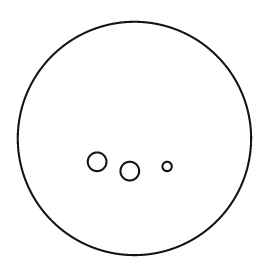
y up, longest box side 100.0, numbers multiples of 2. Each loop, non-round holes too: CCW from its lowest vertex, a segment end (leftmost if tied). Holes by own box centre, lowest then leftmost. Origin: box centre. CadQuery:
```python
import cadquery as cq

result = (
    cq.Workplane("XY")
    .moveTo(0.0, 0.0)
    .circle(50.0)
    .moveTo(-2.0, -14.0)
    .circle(4.0)
    .moveTo(14.0, -12.0)
    .circle(2.0)
    .moveTo(-16.0, -10.0)
    .circle(4.0)
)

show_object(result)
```